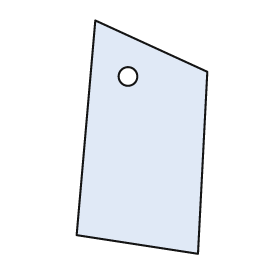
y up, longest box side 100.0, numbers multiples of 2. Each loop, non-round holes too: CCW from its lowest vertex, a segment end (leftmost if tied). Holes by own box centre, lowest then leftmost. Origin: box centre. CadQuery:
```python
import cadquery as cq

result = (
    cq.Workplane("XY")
    .moveTo(24.0, -50.0)
    .lineTo(28.0, 28.0)
    .lineTo(-20.0, 50.0)
    .lineTo(-28.0, -42.0)
    .close()
    .moveTo(-6.0, 26.0)
    .circle(4.0)
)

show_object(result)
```